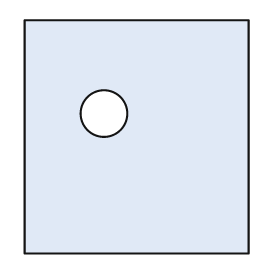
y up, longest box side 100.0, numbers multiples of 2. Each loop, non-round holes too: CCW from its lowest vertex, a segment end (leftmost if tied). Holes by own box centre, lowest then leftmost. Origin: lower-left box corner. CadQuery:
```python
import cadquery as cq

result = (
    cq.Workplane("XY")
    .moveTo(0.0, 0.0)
    .lineTo(96.0, 0.0)
    .lineTo(96.0, 100.0)
    .lineTo(0.0, 100.0)
    .close()
    .moveTo(34.0, 60.0)
    .circle(10.0)
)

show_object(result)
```